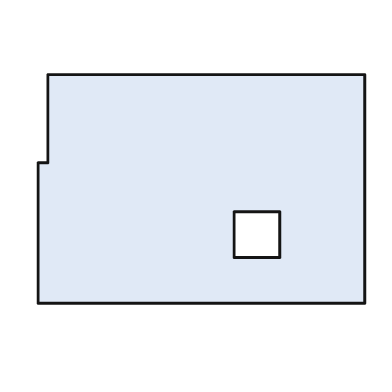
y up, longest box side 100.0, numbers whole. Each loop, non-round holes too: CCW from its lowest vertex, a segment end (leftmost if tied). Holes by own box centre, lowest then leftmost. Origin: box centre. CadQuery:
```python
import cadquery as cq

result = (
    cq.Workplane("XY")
    .moveTo(-50.0, -35.0)
    .lineTo(50.0, -35.0)
    .lineTo(50.0, 35.0)
    .lineTo(-47.0, 35.0)
    .lineTo(-47.0, 8.0)
    .lineTo(-50.0, 8.0)
    .close()
    .moveTo(10.0, -21.0)
    .lineTo(24.0, -21.0)
    .lineTo(24.0, -7.0)
    .lineTo(10.0, -7.0)
    .close()
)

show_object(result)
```